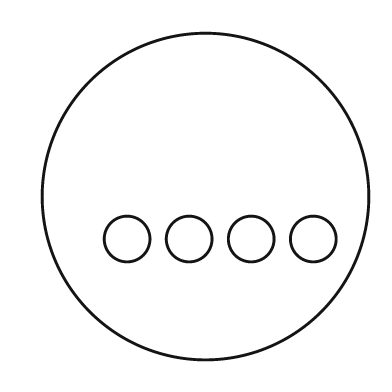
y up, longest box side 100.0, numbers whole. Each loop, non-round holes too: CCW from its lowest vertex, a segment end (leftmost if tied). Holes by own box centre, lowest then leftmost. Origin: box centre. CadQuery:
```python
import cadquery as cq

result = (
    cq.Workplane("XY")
    .moveTo(0.0, 0.0)
    .circle(50.0)
    .moveTo(-24.0, -13.0)
    .circle(7.0)
    .moveTo(-5.0, -13.0)
    .circle(7.0)
    .moveTo(14.0, -13.0)
    .circle(7.0)
    .moveTo(33.0, -13.0)
    .circle(7.0)
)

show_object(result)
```